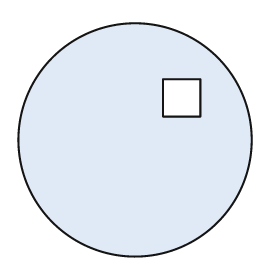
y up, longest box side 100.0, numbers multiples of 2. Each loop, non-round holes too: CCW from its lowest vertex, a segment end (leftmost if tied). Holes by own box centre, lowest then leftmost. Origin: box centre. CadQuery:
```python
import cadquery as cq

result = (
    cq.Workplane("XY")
    .moveTo(0.0, 0.0)
    .circle(50.0)
    .moveTo(12.0, 10.0)
    .lineTo(28.0, 10.0)
    .lineTo(28.0, 26.0)
    .lineTo(12.0, 26.0)
    .close()
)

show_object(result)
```